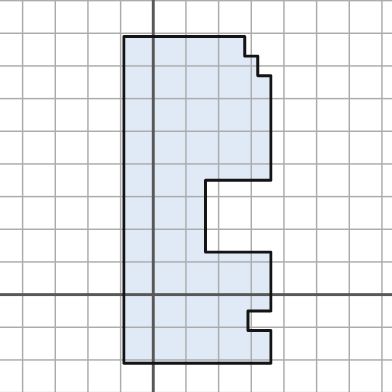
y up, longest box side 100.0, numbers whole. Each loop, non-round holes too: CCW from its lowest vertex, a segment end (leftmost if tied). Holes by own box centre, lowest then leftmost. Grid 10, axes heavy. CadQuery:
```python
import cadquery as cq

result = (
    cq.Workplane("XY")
    .moveTo(-9.0, -21.0)
    .lineTo(36.0, -21.0)
    .lineTo(36.0, -11.0)
    .lineTo(29.0, -11.0)
    .lineTo(29.0, -5.0)
    .lineTo(36.0, -5.0)
    .lineTo(36.0, 13.0)
    .lineTo(16.0, 13.0)
    .lineTo(16.0, 35.0)
    .lineTo(36.0, 35.0)
    .lineTo(36.0, 67.0)
    .lineTo(32.0, 67.0)
    .lineTo(32.0, 73.0)
    .lineTo(28.0, 73.0)
    .lineTo(28.0, 79.0)
    .lineTo(-9.0, 79.0)
    .close()
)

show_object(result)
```